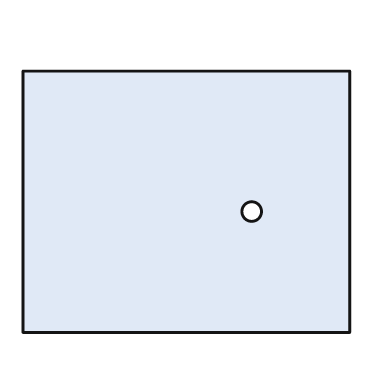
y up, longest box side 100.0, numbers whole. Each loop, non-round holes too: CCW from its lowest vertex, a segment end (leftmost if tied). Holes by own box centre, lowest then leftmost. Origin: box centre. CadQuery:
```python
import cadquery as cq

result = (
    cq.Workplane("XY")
    .moveTo(-50.0, -40.0)
    .lineTo(50.0, -40.0)
    .lineTo(50.0, 40.0)
    .lineTo(-50.0, 40.0)
    .close()
    .moveTo(20.0, -3.0)
    .circle(3.0)
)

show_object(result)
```